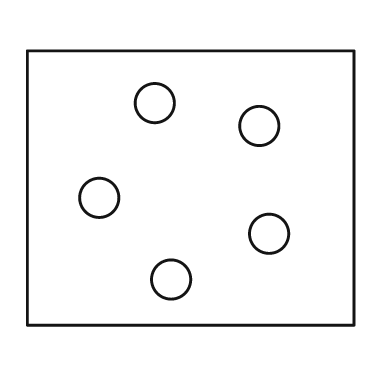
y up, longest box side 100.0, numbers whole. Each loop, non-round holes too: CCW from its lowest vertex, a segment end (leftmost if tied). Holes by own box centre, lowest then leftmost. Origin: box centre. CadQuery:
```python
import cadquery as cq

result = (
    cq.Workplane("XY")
    .moveTo(-50.0, -42.0)
    .lineTo(50.0, -42.0)
    .lineTo(50.0, 42.0)
    .lineTo(-50.0, 42.0)
    .close()
    .moveTo(-6.0, -28.0)
    .circle(6.0)
    .moveTo(24.0, -14.0)
    .circle(6.0)
    .moveTo(-28.0, -3.0)
    .circle(6.0)
    .moveTo(21.0, 19.0)
    .circle(6.0)
    .moveTo(-11.0, 26.0)
    .circle(6.0)
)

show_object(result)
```